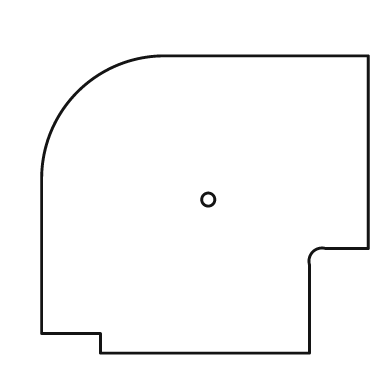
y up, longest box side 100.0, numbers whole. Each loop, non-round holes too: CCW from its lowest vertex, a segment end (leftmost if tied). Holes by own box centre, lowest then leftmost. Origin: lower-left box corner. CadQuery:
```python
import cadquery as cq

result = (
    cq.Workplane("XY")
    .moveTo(18.0, 0.0)
    .lineTo(82.0, 0.0)
    .lineTo(82.0, 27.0)
    .threePointArc((83.0, 31.0), (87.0, 32.0))
    .lineTo(100.0, 32.0)
    .lineTo(100.0, 91.0)
    .lineTo(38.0, 91.0)
    .threePointArc((11.0, 80.0), (0.0, 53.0))
    .lineTo(0.0, 6.0)
    .lineTo(18.0, 6.0)
    .close()
    .moveTo(51.0, 47.0)
    .circle(2.0)
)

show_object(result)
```